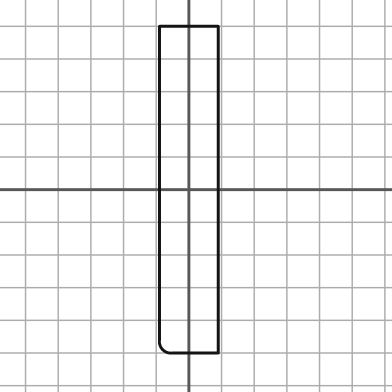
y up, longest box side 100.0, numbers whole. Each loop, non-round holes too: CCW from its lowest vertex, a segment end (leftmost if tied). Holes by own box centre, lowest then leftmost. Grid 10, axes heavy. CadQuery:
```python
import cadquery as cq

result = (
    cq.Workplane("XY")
    .moveTo(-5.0, -50.0)
    .lineTo(9.0, -50.0)
    .lineTo(9.0, 50.0)
    .lineTo(-9.0, 50.0)
    .lineTo(-9.0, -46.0)
    .threePointArc((-8.0, -49.0), (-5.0, -50.0))
    .close()
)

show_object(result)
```